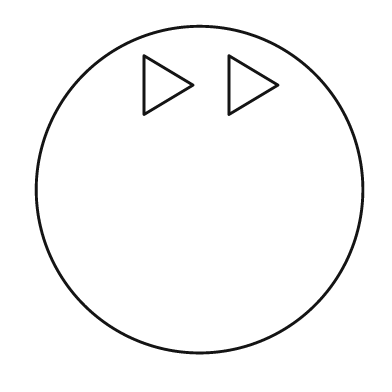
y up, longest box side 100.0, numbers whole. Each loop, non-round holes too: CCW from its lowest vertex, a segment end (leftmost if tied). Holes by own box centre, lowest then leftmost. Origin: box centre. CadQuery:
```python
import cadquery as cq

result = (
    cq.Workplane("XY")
    .moveTo(0.0, 0.0)
    .circle(50.0)
    .moveTo(-17.0, 23.0)
    .lineTo(-2.0, 32.0)
    .lineTo(-17.0, 41.0)
    .close()
    .moveTo(9.0, 23.0)
    .lineTo(24.0, 32.0)
    .lineTo(9.0, 41.0)
    .close()
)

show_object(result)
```